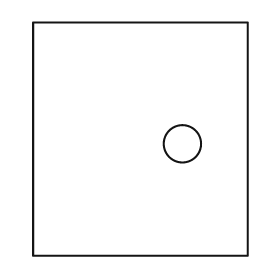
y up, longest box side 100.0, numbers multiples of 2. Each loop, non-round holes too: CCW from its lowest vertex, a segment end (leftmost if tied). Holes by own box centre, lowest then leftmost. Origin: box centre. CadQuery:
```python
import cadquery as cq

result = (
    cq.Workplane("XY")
    .moveTo(-46.0, -50.0)
    .lineTo(46.0, -50.0)
    .lineTo(46.0, 50.0)
    .lineTo(-46.0, 50.0)
    .close()
    .moveTo(18.0, -2.0)
    .circle(8.0)
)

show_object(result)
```